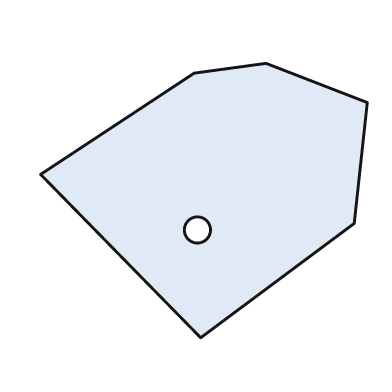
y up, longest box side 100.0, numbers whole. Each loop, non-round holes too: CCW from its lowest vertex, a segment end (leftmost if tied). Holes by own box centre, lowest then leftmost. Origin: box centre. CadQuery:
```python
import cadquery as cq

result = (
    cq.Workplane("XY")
    .moveTo(-1.0, -42.0)
    .lineTo(46.0, -7.0)
    .lineTo(50.0, 30.0)
    .lineTo(19.0, 42.0)
    .lineTo(-3.0, 39.0)
    .lineTo(-50.0, 8.0)
    .close()
    .moveTo(-2.0, -9.0)
    .circle(4.0)
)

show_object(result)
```